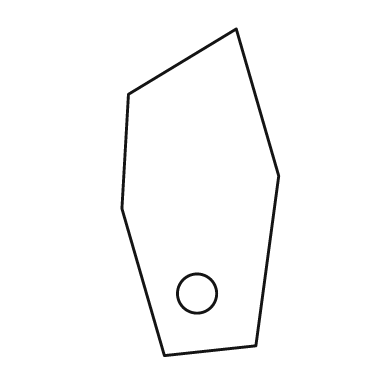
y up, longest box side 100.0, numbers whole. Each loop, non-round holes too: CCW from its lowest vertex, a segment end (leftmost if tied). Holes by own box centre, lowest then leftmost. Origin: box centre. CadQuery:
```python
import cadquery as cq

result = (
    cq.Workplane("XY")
    .moveTo(-11.0, -50.0)
    .lineTo(17.0, -47.0)
    .lineTo(24.0, 5.0)
    .lineTo(11.0, 50.0)
    .lineTo(-22.0, 30.0)
    .lineTo(-24.0, -5.0)
    .close()
    .moveTo(-1.0, -31.0)
    .circle(6.0)
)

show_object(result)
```